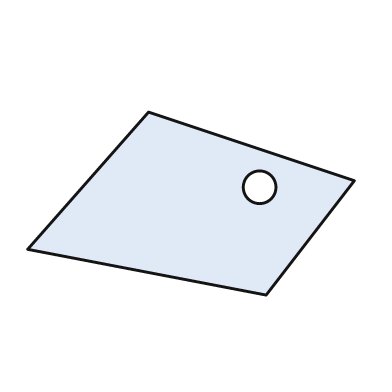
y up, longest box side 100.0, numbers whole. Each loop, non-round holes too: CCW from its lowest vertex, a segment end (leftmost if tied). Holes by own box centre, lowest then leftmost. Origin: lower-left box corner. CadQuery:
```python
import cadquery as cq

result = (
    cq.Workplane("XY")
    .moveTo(73.0, 0.0)
    .lineTo(100.0, 35.0)
    .lineTo(37.0, 56.0)
    .lineTo(0.0, 14.0)
    .close()
    .moveTo(71.0, 33.0)
    .circle(5.0)
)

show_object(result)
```